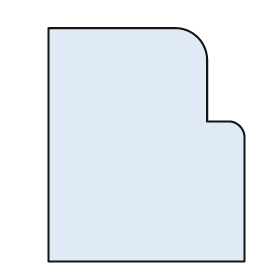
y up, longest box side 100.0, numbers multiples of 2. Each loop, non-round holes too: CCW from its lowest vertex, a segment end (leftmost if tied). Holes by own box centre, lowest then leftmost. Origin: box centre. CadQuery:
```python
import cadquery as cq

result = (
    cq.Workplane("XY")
    .moveTo(-42.0, -50.0)
    .lineTo(42.0, -50.0)
    .lineTo(42.0, 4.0)
    .threePointArc((40.0, 8.0), (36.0, 10.0))
    .lineTo(26.0, 10.0)
    .lineTo(26.0, 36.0)
    .threePointArc((22.0, 46.0), (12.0, 50.0))
    .lineTo(-42.0, 50.0)
    .close()
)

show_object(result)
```